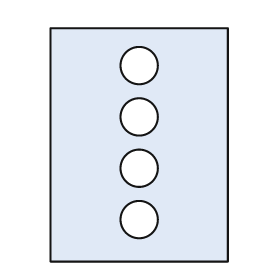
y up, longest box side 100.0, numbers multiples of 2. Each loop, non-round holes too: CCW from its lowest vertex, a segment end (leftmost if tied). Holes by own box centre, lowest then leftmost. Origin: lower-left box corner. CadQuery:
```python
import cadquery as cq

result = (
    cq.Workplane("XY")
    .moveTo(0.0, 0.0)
    .lineTo(76.0, 0.0)
    .lineTo(76.0, 100.0)
    .lineTo(0.0, 100.0)
    .close()
    .moveTo(38.0, 18.0)
    .circle(8.0)
    .moveTo(38.0, 40.0)
    .circle(8.0)
    .moveTo(38.0, 62.0)
    .circle(8.0)
    .moveTo(38.0, 84.0)
    .circle(8.0)
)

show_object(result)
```